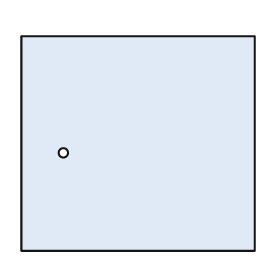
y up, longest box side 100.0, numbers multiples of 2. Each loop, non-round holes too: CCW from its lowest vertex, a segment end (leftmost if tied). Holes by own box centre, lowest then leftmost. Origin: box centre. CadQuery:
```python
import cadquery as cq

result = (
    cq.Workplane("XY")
    .moveTo(-50.0, -46.0)
    .lineTo(50.0, -46.0)
    .lineTo(50.0, 46.0)
    .lineTo(-50.0, 46.0)
    .close()
    .moveTo(-32.0, -4.0)
    .circle(2.0)
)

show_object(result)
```